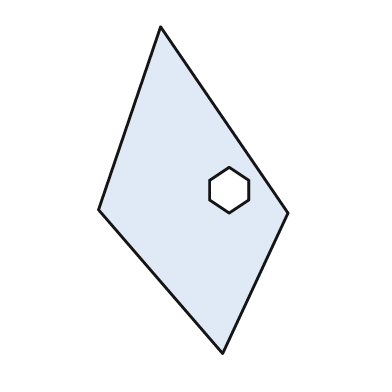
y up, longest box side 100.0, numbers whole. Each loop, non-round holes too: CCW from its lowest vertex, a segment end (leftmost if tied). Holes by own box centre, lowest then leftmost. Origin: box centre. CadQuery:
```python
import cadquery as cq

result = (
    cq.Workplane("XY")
    .moveTo(9.0, -50.0)
    .lineTo(29.0, -7.0)
    .lineTo(-10.0, 50.0)
    .lineTo(-29.0, -6.0)
    .close()
    .moveTo(11.0, -7.0)
    .lineTo(17.0, -3.0)
    .lineTo(17.0, 3.0)
    .lineTo(11.0, 7.0)
    .lineTo(5.0, 3.0)
    .lineTo(5.0, -3.0)
    .close()
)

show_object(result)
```